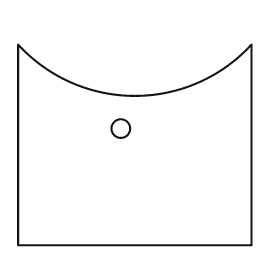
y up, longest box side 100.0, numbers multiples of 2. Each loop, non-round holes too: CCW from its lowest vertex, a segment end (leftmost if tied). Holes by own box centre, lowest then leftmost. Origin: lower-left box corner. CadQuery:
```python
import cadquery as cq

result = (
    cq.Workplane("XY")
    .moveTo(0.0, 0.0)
    .lineTo(100.0, 0.0)
    .lineTo(100.0, 86.0)
    .threePointArc((50.0, 64.0), (0.0, 86.0))
    .close()
    .moveTo(44.0, 50.0)
    .circle(4.0)
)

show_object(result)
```